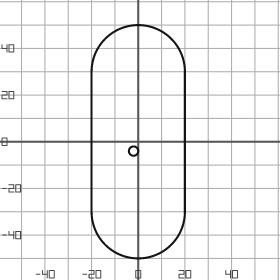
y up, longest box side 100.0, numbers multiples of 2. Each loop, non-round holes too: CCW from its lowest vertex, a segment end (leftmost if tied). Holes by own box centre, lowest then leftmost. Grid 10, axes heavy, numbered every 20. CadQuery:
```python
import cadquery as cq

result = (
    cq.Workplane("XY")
    .moveTo(-20.0, -30.0)
    .threePointArc((0.0, -50.0), (20.0, -30.0))
    .lineTo(20.0, 30.0)
    .threePointArc((0.0, 50.0), (-20.0, 30.0))
    .close()
    .moveTo(-2.0, -4.0)
    .circle(2.0)
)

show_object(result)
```